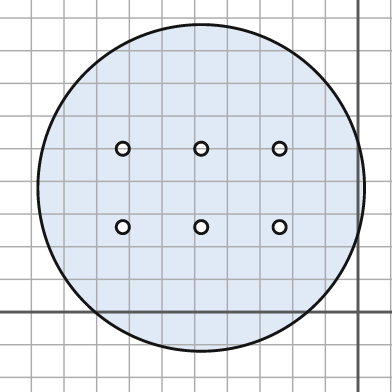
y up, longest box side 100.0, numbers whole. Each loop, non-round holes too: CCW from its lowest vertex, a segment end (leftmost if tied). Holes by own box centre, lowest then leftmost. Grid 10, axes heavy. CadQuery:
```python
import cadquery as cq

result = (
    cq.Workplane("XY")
    .moveTo(-48.0, 38.0)
    .circle(50.0)
    .moveTo(-72.0, 26.0)
    .circle(2.0)
    .moveTo(-48.0, 26.0)
    .circle(2.0)
    .moveTo(-24.0, 26.0)
    .circle(2.0)
    .moveTo(-72.0, 50.0)
    .circle(2.0)
    .moveTo(-48.0, 50.0)
    .circle(2.0)
    .moveTo(-24.0, 50.0)
    .circle(2.0)
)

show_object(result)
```